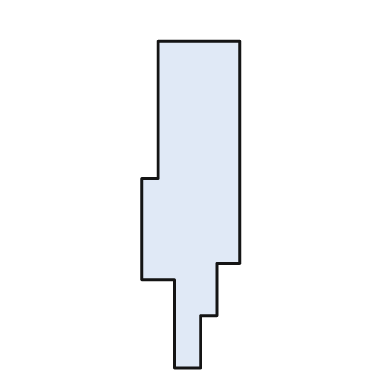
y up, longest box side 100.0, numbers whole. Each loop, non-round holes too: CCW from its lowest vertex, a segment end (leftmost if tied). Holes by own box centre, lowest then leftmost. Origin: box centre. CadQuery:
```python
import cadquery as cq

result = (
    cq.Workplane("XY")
    .moveTo(-5.0, -50.0)
    .lineTo(3.0, -50.0)
    .lineTo(3.0, -34.0)
    .lineTo(8.0, -34.0)
    .lineTo(8.0, -18.0)
    .lineTo(15.0, -18.0)
    .lineTo(15.0, 50.0)
    .lineTo(-10.0, 50.0)
    .lineTo(-10.0, 8.0)
    .lineTo(-15.0, 8.0)
    .lineTo(-15.0, -23.0)
    .lineTo(-5.0, -23.0)
    .close()
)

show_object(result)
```